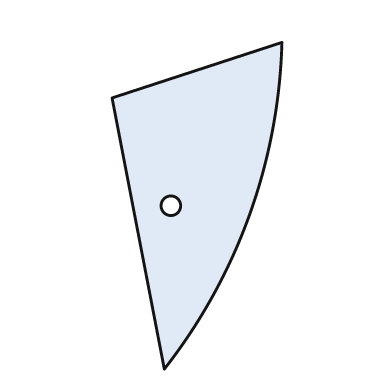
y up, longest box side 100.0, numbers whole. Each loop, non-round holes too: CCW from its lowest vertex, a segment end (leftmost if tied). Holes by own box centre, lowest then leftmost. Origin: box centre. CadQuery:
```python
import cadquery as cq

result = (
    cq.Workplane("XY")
    .moveTo(-10.0, -50.0)
    .threePointArc((16.0, -3.0), (26.0, 50.0))
    .lineTo(-26.0, 33.0)
    .close()
    .moveTo(-8.0, 0.0)
    .circle(3.0)
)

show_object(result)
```